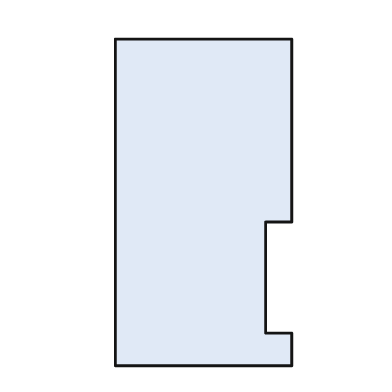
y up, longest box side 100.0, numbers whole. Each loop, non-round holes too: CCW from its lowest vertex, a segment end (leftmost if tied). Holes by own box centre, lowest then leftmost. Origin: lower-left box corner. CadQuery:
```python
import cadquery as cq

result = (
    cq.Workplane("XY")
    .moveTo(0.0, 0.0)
    .lineTo(54.0, 0.0)
    .lineTo(54.0, 10.0)
    .lineTo(46.0, 10.0)
    .lineTo(46.0, 44.0)
    .lineTo(54.0, 44.0)
    .lineTo(54.0, 100.0)
    .lineTo(0.0, 100.0)
    .close()
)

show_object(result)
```